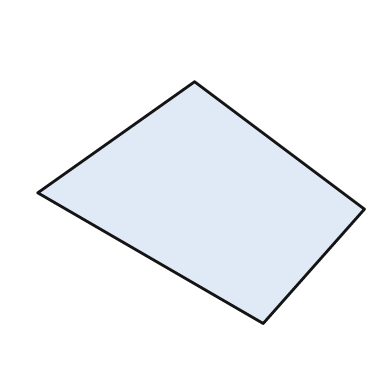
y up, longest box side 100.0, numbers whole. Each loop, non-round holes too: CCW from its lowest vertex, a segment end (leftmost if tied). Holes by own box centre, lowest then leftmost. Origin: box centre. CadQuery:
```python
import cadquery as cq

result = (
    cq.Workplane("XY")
    .moveTo(19.0, -37.0)
    .lineTo(50.0, -2.0)
    .lineTo(-2.0, 37.0)
    .lineTo(-50.0, 3.0)
    .close()
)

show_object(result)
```